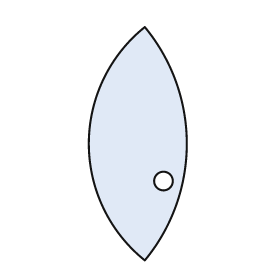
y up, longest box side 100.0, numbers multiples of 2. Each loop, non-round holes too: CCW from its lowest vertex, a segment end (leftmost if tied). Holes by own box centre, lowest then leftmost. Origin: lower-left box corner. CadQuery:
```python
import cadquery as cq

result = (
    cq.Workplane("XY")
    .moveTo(24.0, 0.0)
    .threePointArc((42.0, 50.0), (24.0, 100.0))
    .threePointArc((0.0, 50.0), (24.0, 0.0))
    .close()
    .moveTo(32.0, 34.0)
    .circle(4.0)
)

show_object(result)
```